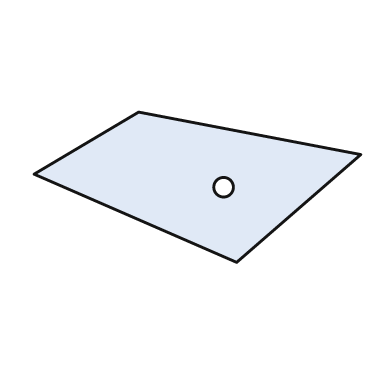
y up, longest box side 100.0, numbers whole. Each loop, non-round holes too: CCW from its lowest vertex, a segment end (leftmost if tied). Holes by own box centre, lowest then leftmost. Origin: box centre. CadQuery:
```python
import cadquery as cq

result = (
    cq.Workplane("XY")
    .moveTo(12.0, -23.0)
    .lineTo(50.0, 10.0)
    .lineTo(-18.0, 23.0)
    .lineTo(-50.0, 4.0)
    .close()
    .moveTo(8.0, 0.0)
    .circle(3.0)
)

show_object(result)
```